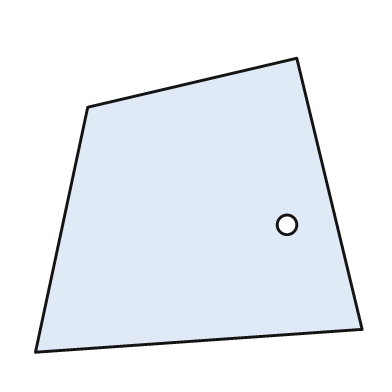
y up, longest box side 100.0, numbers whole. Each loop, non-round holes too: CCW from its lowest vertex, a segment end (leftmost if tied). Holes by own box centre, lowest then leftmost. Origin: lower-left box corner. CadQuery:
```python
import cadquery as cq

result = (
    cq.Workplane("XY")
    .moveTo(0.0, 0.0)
    .lineTo(100.0, 7.0)
    .lineTo(80.0, 90.0)
    .lineTo(16.0, 75.0)
    .close()
    .moveTo(77.0, 39.0)
    .circle(3.0)
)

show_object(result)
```